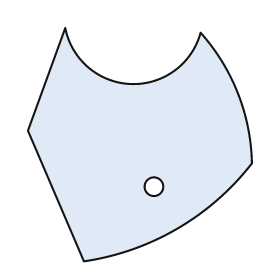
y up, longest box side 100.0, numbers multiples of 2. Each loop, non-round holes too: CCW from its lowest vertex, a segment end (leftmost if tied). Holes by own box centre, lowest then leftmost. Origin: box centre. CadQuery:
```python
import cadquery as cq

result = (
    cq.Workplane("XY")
    .moveTo(-24.0, -50.0)
    .threePointArc((16.0, -36.0), (48.0, -8.0))
    .threePointArc((42.0, 22.0), (26.0, 48.0))
    .threePointArc((-4.0, 26.0), (-32.0, 50.0))
    .lineTo(-48.0, 6.0)
    .close()
    .moveTo(6.0, -18.0)
    .circle(4.0)
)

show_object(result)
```